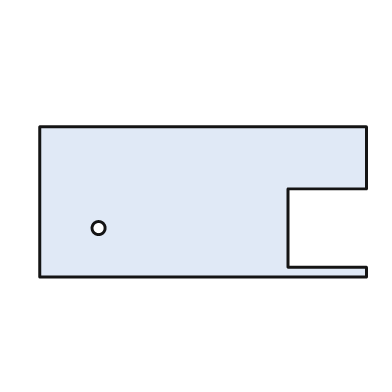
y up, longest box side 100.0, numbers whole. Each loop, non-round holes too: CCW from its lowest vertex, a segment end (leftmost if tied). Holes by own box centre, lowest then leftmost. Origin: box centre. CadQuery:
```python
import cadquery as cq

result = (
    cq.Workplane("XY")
    .moveTo(-50.0, -23.0)
    .lineTo(50.0, -23.0)
    .lineTo(50.0, -20.0)
    .lineTo(26.0, -20.0)
    .lineTo(26.0, 4.0)
    .lineTo(50.0, 4.0)
    .lineTo(50.0, 23.0)
    .lineTo(-50.0, 23.0)
    .close()
    .moveTo(-32.0, -8.0)
    .circle(2.0)
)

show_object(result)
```